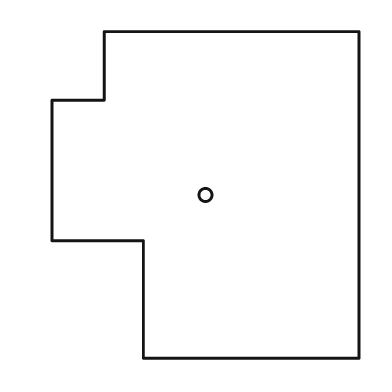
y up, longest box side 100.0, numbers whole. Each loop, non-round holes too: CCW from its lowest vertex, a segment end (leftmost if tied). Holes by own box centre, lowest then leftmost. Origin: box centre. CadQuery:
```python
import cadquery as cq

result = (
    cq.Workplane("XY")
    .moveTo(-19.0, -50.0)
    .lineTo(47.0, -50.0)
    .lineTo(47.0, 50.0)
    .lineTo(-31.0, 50.0)
    .lineTo(-31.0, 29.0)
    .lineTo(-47.0, 29.0)
    .lineTo(-47.0, -14.0)
    .lineTo(-19.0, -14.0)
    .close()
    .moveTo(0.0, 0.0)
    .circle(2.0)
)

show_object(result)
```